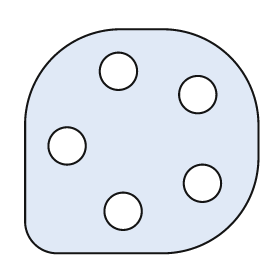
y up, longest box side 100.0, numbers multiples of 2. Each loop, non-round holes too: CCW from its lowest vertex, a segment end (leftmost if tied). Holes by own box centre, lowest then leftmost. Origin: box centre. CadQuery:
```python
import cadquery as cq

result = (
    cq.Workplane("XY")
    .moveTo(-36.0, -48.0)
    .lineTo(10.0, -48.0)
    .threePointArc((38.0, -36.0), (50.0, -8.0))
    .lineTo(50.0, 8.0)
    .threePointArc((38.0, 36.0), (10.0, 48.0))
    .lineTo(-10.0, 48.0)
    .threePointArc((-38.0, 36.0), (-50.0, 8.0))
    .lineTo(-50.0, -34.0)
    .threePointArc((-46.0, -44.0), (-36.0, -48.0))
    .close()
    .moveTo(-8.0, -30.0)
    .circle(8.0)
    .moveTo(26.0, -18.0)
    .circle(8.0)
    .moveTo(-32.0, -2.0)
    .circle(8.0)
    .moveTo(24.0, 20.0)
    .circle(8.0)
    .moveTo(-10.0, 30.0)
    .circle(8.0)
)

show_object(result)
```